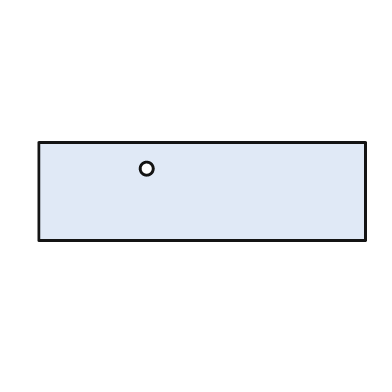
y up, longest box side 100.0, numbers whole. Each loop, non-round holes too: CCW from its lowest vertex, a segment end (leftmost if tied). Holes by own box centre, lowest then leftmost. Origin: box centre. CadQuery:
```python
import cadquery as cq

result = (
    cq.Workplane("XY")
    .moveTo(-50.0, -15.0)
    .lineTo(50.0, -15.0)
    .lineTo(50.0, 15.0)
    .lineTo(-50.0, 15.0)
    .close()
    .moveTo(-17.0, 7.0)
    .circle(2.0)
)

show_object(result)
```